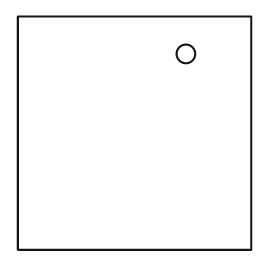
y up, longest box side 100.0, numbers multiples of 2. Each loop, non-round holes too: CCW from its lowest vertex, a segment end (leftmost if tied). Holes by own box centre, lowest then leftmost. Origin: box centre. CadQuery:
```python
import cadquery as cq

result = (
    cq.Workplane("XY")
    .moveTo(-50.0, -50.0)
    .lineTo(50.0, -50.0)
    .lineTo(50.0, 50.0)
    .lineTo(-50.0, 50.0)
    .close()
    .moveTo(22.0, 34.0)
    .circle(4.0)
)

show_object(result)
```